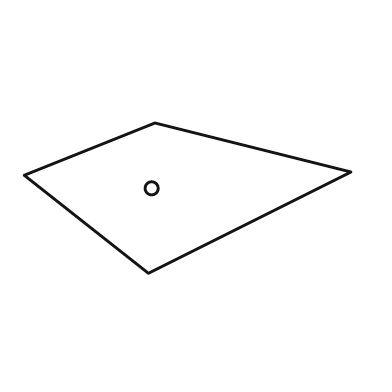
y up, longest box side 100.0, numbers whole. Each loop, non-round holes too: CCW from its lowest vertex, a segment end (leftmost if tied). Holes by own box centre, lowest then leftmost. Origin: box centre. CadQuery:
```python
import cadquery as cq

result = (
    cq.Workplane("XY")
    .moveTo(-12.0, -23.0)
    .lineTo(50.0, 8.0)
    .lineTo(-10.0, 23.0)
    .lineTo(-50.0, 7.0)
    .close()
    .moveTo(-11.0, 3.0)
    .circle(2.0)
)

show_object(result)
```